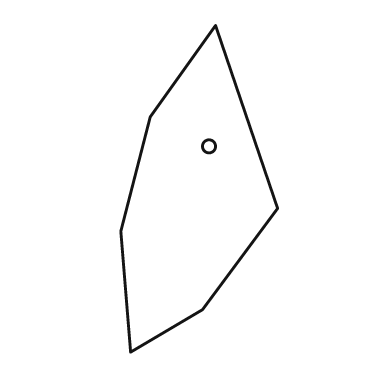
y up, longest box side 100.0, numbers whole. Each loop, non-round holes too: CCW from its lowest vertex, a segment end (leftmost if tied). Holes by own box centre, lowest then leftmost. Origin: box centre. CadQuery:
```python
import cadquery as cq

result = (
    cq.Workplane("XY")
    .moveTo(-21.0, -50.0)
    .lineTo(1.0, -37.0)
    .lineTo(24.0, -6.0)
    .lineTo(5.0, 50.0)
    .lineTo(-15.0, 22.0)
    .lineTo(-24.0, -13.0)
    .close()
    .moveTo(3.0, 13.0)
    .circle(2.0)
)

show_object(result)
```